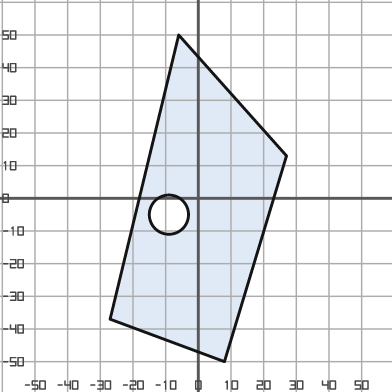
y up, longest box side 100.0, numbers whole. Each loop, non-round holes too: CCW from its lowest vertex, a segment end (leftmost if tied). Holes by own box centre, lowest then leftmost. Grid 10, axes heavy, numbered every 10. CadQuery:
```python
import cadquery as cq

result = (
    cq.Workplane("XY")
    .moveTo(8.0, -50.0)
    .lineTo(27.0, 13.0)
    .lineTo(-6.0, 50.0)
    .lineTo(-27.0, -37.0)
    .close()
    .moveTo(-9.0, -5.0)
    .circle(6.0)
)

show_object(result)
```